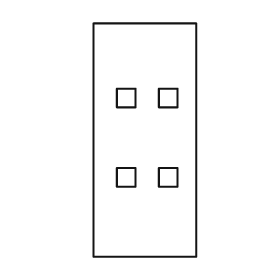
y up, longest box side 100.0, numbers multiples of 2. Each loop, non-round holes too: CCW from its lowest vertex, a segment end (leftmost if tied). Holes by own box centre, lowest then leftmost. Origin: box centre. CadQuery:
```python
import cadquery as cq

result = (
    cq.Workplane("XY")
    .moveTo(-22.0, -50.0)
    .lineTo(22.0, -50.0)
    .lineTo(22.0, 50.0)
    .lineTo(-22.0, 50.0)
    .close()
    .moveTo(-12.0, -20.0)
    .lineTo(-4.0, -20.0)
    .lineTo(-4.0, -12.0)
    .lineTo(-12.0, -12.0)
    .close()
    .moveTo(6.0, -20.0)
    .lineTo(14.0, -20.0)
    .lineTo(14.0, -12.0)
    .lineTo(6.0, -12.0)
    .close()
    .moveTo(-12.0, 14.0)
    .lineTo(-4.0, 14.0)
    .lineTo(-4.0, 22.0)
    .lineTo(-12.0, 22.0)
    .close()
    .moveTo(6.0, 14.0)
    .lineTo(14.0, 14.0)
    .lineTo(14.0, 22.0)
    .lineTo(6.0, 22.0)
    .close()
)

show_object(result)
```